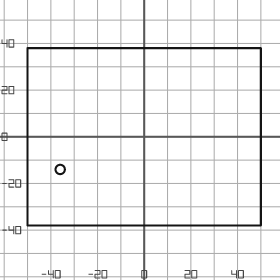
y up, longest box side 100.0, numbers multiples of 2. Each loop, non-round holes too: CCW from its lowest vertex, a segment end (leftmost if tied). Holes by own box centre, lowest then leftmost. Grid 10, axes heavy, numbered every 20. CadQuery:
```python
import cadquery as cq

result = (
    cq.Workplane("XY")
    .moveTo(-50.0, -38.0)
    .lineTo(50.0, -38.0)
    .lineTo(50.0, 38.0)
    .lineTo(-50.0, 38.0)
    .close()
    .moveTo(-36.0, -14.0)
    .circle(2.0)
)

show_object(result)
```